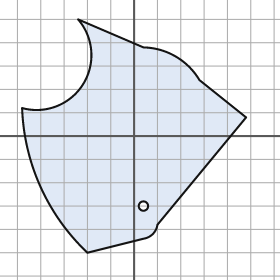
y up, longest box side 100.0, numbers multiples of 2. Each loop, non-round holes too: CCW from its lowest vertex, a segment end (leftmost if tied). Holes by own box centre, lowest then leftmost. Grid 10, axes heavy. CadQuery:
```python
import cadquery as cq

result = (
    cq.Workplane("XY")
    .moveTo(-20.0, -50.0)
    .lineTo(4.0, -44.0)
    .threePointArc((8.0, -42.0), (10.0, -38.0))
    .lineTo(48.0, 8.0)
    .lineTo(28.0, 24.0)
    .threePointArc((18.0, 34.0), (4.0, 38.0))
    .lineTo(-24.0, 50.0)
    .threePointArc((-22.0, 22.0), (-48.0, 12.0))
    .threePointArc((-40.0, -22.0), (-20.0, -50.0))
    .close()
    .moveTo(4.0, -30.0)
    .circle(2.0)
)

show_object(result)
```